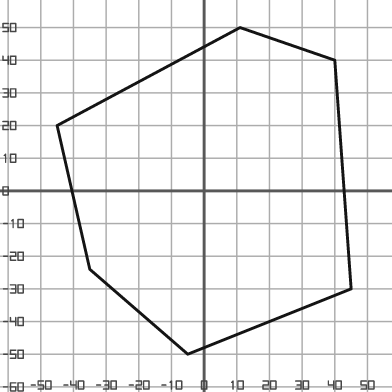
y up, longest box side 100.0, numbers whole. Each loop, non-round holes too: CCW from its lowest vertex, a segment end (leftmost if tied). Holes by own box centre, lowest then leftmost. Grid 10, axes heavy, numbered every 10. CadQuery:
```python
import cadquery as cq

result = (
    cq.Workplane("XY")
    .moveTo(-5.0, -50.0)
    .lineTo(45.0, -30.0)
    .lineTo(40.0, 40.0)
    .lineTo(11.0, 50.0)
    .lineTo(-45.0, 20.0)
    .lineTo(-35.0, -24.0)
    .close()
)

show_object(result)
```